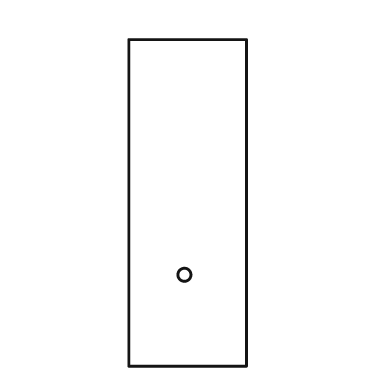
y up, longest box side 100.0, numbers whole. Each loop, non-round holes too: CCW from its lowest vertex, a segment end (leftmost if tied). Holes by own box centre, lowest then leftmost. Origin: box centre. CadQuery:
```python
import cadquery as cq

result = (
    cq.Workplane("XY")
    .moveTo(-18.0, -50.0)
    .lineTo(18.0, -50.0)
    .lineTo(18.0, 50.0)
    .lineTo(-18.0, 50.0)
    .close()
    .moveTo(-1.0, -22.0)
    .circle(2.0)
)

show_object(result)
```